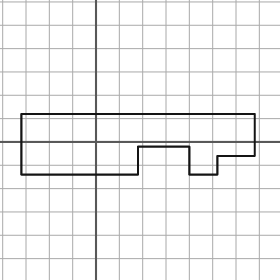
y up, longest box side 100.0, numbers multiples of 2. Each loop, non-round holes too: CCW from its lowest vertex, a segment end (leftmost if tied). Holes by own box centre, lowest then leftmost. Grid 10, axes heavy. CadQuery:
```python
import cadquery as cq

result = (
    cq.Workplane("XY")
    .moveTo(-32.0, -14.0)
    .lineTo(18.0, -14.0)
    .lineTo(18.0, -2.0)
    .lineTo(40.0, -2.0)
    .lineTo(40.0, -14.0)
    .lineTo(52.0, -14.0)
    .lineTo(52.0, -6.0)
    .lineTo(68.0, -6.0)
    .lineTo(68.0, 12.0)
    .lineTo(-32.0, 12.0)
    .close()
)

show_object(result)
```